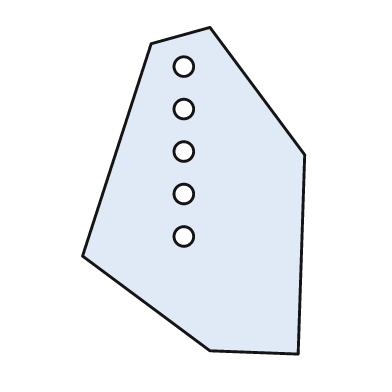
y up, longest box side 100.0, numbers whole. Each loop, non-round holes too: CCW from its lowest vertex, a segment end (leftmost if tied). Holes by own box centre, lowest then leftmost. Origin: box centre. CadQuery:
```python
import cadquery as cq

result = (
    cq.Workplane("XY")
    .moveTo(32.0, -50.0)
    .lineTo(34.0, 11.0)
    .lineTo(5.0, 50.0)
    .lineTo(-13.0, 45.0)
    .lineTo(-34.0, -20.0)
    .lineTo(5.0, -49.0)
    .close()
    .moveTo(-3.0, -14.0)
    .circle(3.0)
    .moveTo(-3.0, -1.0)
    .circle(3.0)
    .moveTo(-3.0, 12.0)
    .circle(3.0)
    .moveTo(-3.0, 25.0)
    .circle(3.0)
    .moveTo(-3.0, 38.0)
    .circle(3.0)
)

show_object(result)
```